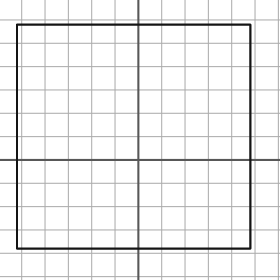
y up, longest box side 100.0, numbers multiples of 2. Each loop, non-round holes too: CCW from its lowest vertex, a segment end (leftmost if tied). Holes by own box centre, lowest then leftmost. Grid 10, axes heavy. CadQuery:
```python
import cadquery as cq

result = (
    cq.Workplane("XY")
    .moveTo(-52.0, -38.0)
    .lineTo(48.0, -38.0)
    .lineTo(48.0, 58.0)
    .lineTo(-52.0, 58.0)
    .close()
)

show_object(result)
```